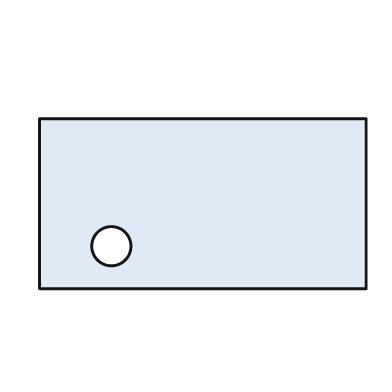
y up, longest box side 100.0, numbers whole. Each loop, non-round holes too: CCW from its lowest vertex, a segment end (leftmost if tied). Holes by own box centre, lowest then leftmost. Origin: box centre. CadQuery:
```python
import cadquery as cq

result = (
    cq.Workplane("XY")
    .moveTo(-50.0, -26.0)
    .lineTo(50.0, -26.0)
    .lineTo(50.0, 26.0)
    .lineTo(-50.0, 26.0)
    .close()
    .moveTo(-28.0, -13.0)
    .circle(6.0)
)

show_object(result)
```